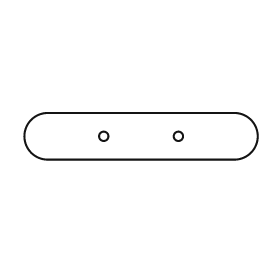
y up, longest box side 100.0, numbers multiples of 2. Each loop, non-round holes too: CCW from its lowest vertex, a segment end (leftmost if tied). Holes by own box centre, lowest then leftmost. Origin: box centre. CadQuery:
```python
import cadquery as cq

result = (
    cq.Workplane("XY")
    .moveTo(-40.0, -10.0)
    .lineTo(40.0, -10.0)
    .threePointArc((50.0, 0.0), (40.0, 10.0))
    .lineTo(-40.0, 10.0)
    .threePointArc((-50.0, 0.0), (-40.0, -10.0))
    .close()
    .moveTo(-16.0, 0.0)
    .circle(2.0)
    .moveTo(16.0, 0.0)
    .circle(2.0)
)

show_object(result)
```